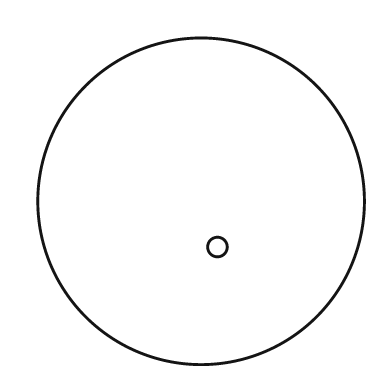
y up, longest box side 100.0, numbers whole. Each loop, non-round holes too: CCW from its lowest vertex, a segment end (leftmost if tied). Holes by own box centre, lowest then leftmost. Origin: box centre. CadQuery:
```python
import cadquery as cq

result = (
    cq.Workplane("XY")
    .moveTo(0.0, 0.0)
    .circle(50.0)
    .moveTo(5.0, -14.0)
    .circle(3.0)
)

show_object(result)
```